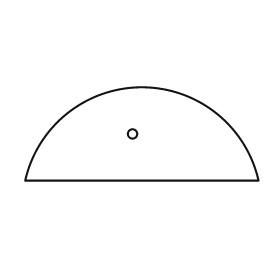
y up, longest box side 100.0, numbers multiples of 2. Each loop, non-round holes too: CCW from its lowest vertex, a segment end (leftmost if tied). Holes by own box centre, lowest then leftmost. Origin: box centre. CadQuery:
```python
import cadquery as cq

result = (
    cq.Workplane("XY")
    .moveTo(-50.0, -20.0)
    .lineTo(50.0, -20.0)
    .threePointArc((0.0, 20.0), (-50.0, -20.0))
    .close()
    .moveTo(-4.0, 0.0)
    .circle(2.0)
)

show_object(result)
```